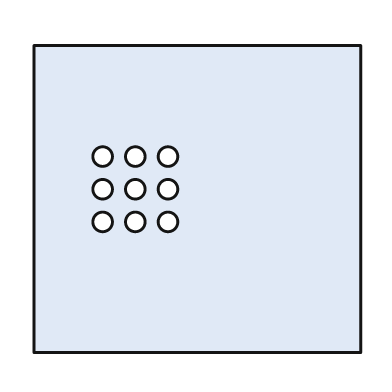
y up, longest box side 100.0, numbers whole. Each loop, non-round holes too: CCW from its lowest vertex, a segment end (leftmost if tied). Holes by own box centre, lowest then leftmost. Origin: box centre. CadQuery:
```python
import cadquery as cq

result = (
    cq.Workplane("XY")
    .moveTo(-50.0, -47.0)
    .lineTo(50.0, -47.0)
    .lineTo(50.0, 47.0)
    .lineTo(-50.0, 47.0)
    .close()
    .moveTo(-29.0, -7.0)
    .circle(3.0)
    .moveTo(-19.0, -7.0)
    .circle(3.0)
    .moveTo(-9.0, -7.0)
    .circle(3.0)
    .moveTo(-29.0, 3.0)
    .circle(3.0)
    .moveTo(-19.0, 3.0)
    .circle(3.0)
    .moveTo(-9.0, 3.0)
    .circle(3.0)
    .moveTo(-29.0, 13.0)
    .circle(3.0)
    .moveTo(-19.0, 13.0)
    .circle(3.0)
    .moveTo(-9.0, 13.0)
    .circle(3.0)
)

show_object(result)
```